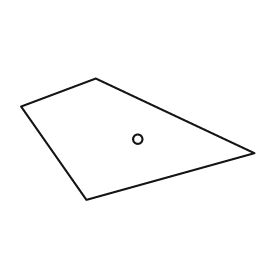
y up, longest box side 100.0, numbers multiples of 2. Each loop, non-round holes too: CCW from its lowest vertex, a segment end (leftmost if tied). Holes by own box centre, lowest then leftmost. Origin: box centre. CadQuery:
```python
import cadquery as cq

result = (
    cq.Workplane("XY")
    .moveTo(-22.0, -26.0)
    .lineTo(50.0, -6.0)
    .lineTo(-18.0, 26.0)
    .lineTo(-50.0, 14.0)
    .close()
    .moveTo(0.0, 0.0)
    .circle(2.0)
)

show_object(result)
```